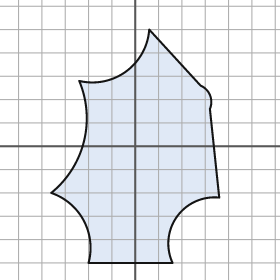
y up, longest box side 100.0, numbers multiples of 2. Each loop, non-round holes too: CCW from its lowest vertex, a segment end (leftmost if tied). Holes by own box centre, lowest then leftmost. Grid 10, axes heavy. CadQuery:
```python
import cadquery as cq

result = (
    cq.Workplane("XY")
    .moveTo(-20.0, -50.0)
    .lineTo(16.0, -50.0)
    .threePointArc((18.0, -30.0), (36.0, -22.0))
    .lineTo(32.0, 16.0)
    .threePointArc((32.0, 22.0), (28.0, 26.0))
    .lineTo(6.0, 50.0)
    .threePointArc((-4.0, 32.0), (-24.0, 28.0))
    .threePointArc((-22.0, 2.0), (-36.0, -20.0))
    .threePointArc((-22.0, -32.0), (-20.0, -50.0))
    .close()
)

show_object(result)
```